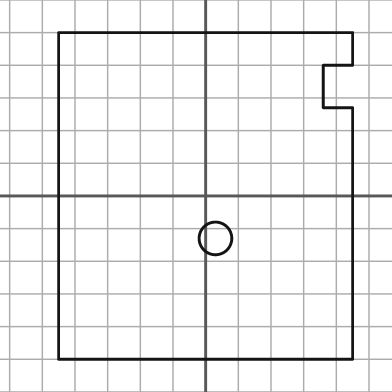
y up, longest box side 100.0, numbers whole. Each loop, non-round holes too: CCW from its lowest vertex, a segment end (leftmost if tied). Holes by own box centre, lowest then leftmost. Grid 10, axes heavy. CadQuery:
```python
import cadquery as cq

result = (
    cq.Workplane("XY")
    .moveTo(-45.0, -50.0)
    .lineTo(45.0, -50.0)
    .lineTo(45.0, 27.0)
    .lineTo(36.0, 27.0)
    .lineTo(36.0, 40.0)
    .lineTo(45.0, 40.0)
    .lineTo(45.0, 50.0)
    .lineTo(-45.0, 50.0)
    .close()
    .moveTo(3.0, -13.0)
    .circle(5.0)
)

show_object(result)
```